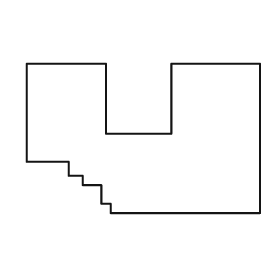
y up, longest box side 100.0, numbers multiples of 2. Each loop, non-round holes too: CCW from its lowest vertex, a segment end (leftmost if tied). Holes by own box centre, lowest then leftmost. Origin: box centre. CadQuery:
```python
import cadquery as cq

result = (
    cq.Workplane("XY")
    .moveTo(-14.0, -32.0)
    .lineTo(50.0, -32.0)
    .lineTo(50.0, 32.0)
    .lineTo(12.0, 32.0)
    .lineTo(12.0, 2.0)
    .lineTo(-16.0, 2.0)
    .lineTo(-16.0, 32.0)
    .lineTo(-50.0, 32.0)
    .lineTo(-50.0, -10.0)
    .lineTo(-32.0, -10.0)
    .lineTo(-32.0, -16.0)
    .lineTo(-26.0, -16.0)
    .lineTo(-26.0, -20.0)
    .lineTo(-18.0, -20.0)
    .lineTo(-18.0, -28.0)
    .lineTo(-14.0, -28.0)
    .close()
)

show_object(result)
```